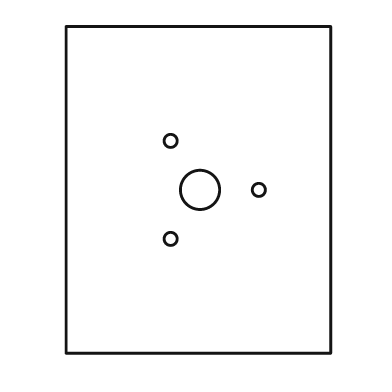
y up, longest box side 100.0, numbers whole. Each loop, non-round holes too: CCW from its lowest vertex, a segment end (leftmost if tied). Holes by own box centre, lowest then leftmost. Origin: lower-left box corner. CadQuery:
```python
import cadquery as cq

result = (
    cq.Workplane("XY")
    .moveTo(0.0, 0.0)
    .lineTo(81.0, 0.0)
    .lineTo(81.0, 100.0)
    .lineTo(0.0, 100.0)
    .close()
    .moveTo(32.0, 35.0)
    .circle(2.0)
    .moveTo(41.0, 50.0)
    .circle(6.0)
    .moveTo(59.0, 50.0)
    .circle(2.0)
    .moveTo(32.0, 65.0)
    .circle(2.0)
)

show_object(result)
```